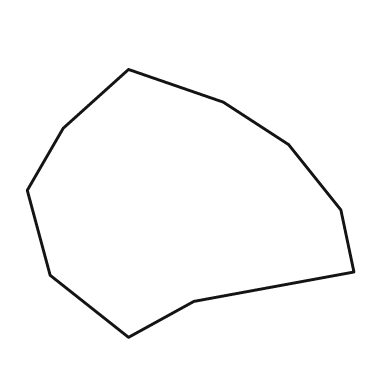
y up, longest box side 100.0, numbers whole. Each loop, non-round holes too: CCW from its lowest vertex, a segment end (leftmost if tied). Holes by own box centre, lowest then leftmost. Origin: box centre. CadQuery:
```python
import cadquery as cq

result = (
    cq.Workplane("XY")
    .moveTo(-19.0, -41.0)
    .lineTo(1.0, -30.0)
    .lineTo(50.0, -21.0)
    .lineTo(46.0, -2.0)
    .lineTo(30.0, 18.0)
    .lineTo(10.0, 31.0)
    .lineTo(-19.0, 41.0)
    .lineTo(-39.0, 23.0)
    .lineTo(-50.0, 4.0)
    .lineTo(-43.0, -22.0)
    .close()
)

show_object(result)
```